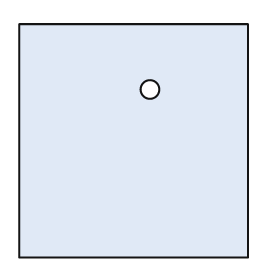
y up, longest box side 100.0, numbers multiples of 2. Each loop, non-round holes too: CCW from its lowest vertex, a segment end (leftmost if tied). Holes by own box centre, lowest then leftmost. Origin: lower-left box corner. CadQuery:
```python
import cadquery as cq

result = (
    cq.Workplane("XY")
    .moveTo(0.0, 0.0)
    .lineTo(98.0, 0.0)
    .lineTo(98.0, 100.0)
    .lineTo(0.0, 100.0)
    .close()
    .moveTo(56.0, 72.0)
    .circle(4.0)
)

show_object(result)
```